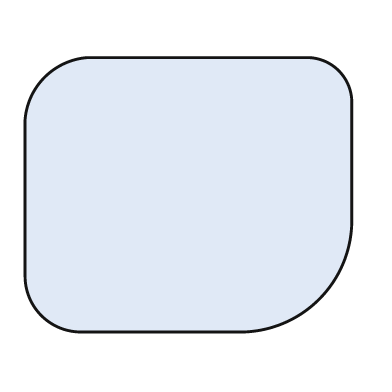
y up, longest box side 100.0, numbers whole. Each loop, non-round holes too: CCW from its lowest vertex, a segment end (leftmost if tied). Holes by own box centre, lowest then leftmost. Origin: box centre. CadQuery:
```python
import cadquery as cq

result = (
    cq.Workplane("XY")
    .moveTo(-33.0, -42.0)
    .lineTo(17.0, -42.0)
    .threePointArc((40.0, -32.0), (50.0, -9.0))
    .lineTo(50.0, 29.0)
    .threePointArc((46.0, 38.0), (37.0, 42.0))
    .lineTo(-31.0, 42.0)
    .threePointArc((-44.0, 36.0), (-50.0, 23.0))
    .lineTo(-50.0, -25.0)
    .threePointArc((-45.0, -37.0), (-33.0, -42.0))
    .close()
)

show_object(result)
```